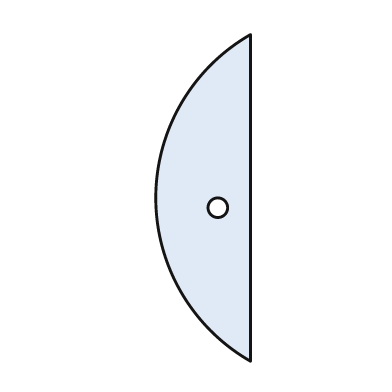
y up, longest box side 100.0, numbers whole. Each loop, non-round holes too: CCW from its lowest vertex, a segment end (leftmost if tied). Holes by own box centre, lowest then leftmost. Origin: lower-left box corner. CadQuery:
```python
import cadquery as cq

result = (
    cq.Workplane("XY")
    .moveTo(29.0, 0.0)
    .lineTo(29.0, 100.0)
    .threePointArc((0.0, 50.0), (29.0, 0.0))
    .close()
    .moveTo(19.0, 47.0)
    .circle(3.0)
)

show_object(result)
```